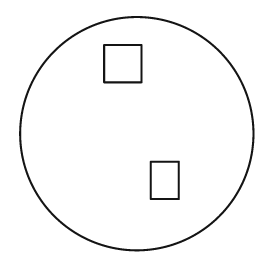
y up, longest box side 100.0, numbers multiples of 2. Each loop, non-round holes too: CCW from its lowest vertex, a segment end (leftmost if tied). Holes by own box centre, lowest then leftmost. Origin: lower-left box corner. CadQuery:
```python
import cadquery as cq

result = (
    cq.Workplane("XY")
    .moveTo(50.0, 50.0)
    .circle(50.0)
    .moveTo(56.0, 22.0)
    .lineTo(68.0, 22.0)
    .lineTo(68.0, 38.0)
    .lineTo(56.0, 38.0)
    .close()
    .moveTo(36.0, 72.0)
    .lineTo(52.0, 72.0)
    .lineTo(52.0, 88.0)
    .lineTo(36.0, 88.0)
    .close()
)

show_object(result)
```